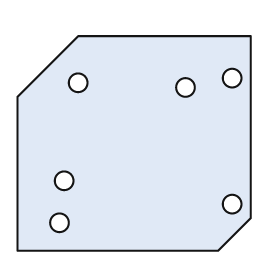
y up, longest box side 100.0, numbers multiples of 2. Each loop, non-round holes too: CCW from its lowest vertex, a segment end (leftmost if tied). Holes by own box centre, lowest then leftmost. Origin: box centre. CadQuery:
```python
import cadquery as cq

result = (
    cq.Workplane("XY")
    .moveTo(-50.0, -46.0)
    .lineTo(36.0, -46.0)
    .lineTo(50.0, -32.0)
    .lineTo(50.0, 46.0)
    .lineTo(-24.0, 46.0)
    .lineTo(-50.0, 20.0)
    .close()
    .moveTo(-32.0, -34.0)
    .circle(4.0)
    .moveTo(42.0, -26.0)
    .circle(4.0)
    .moveTo(-30.0, -16.0)
    .circle(4.0)
    .moveTo(22.0, 24.0)
    .circle(4.0)
    .moveTo(-24.0, 26.0)
    .circle(4.0)
    .moveTo(42.0, 28.0)
    .circle(4.0)
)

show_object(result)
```